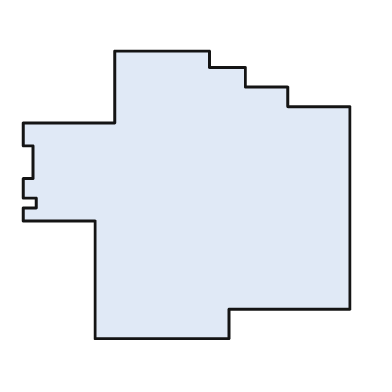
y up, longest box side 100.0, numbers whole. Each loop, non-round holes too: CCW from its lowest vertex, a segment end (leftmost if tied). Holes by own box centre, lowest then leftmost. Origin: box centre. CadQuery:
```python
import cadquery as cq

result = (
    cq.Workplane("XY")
    .moveTo(-28.0, -44.0)
    .lineTo(13.0, -44.0)
    .lineTo(13.0, -35.0)
    .lineTo(50.0, -35.0)
    .lineTo(50.0, 27.0)
    .lineTo(31.0, 27.0)
    .lineTo(31.0, 33.0)
    .lineTo(18.0, 33.0)
    .lineTo(18.0, 39.0)
    .lineTo(7.0, 39.0)
    .lineTo(7.0, 44.0)
    .lineTo(-22.0, 44.0)
    .lineTo(-22.0, 22.0)
    .lineTo(-50.0, 22.0)
    .lineTo(-50.0, 15.0)
    .lineTo(-47.0, 15.0)
    .lineTo(-47.0, 5.0)
    .lineTo(-50.0, 5.0)
    .lineTo(-50.0, -1.0)
    .lineTo(-46.0, -1.0)
    .lineTo(-46.0, -4.0)
    .lineTo(-50.0, -4.0)
    .lineTo(-50.0, -8.0)
    .lineTo(-28.0, -8.0)
    .close()
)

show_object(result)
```